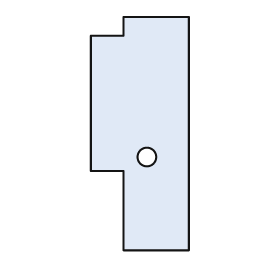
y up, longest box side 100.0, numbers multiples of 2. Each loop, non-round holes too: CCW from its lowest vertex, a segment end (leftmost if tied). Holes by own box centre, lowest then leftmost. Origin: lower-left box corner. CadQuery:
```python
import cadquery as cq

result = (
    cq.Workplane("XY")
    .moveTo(14.0, 0.0)
    .lineTo(42.0, 0.0)
    .lineTo(42.0, 100.0)
    .lineTo(14.0, 100.0)
    .lineTo(14.0, 92.0)
    .lineTo(0.0, 92.0)
    .lineTo(0.0, 34.0)
    .lineTo(14.0, 34.0)
    .close()
    .moveTo(24.0, 40.0)
    .circle(4.0)
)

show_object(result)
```